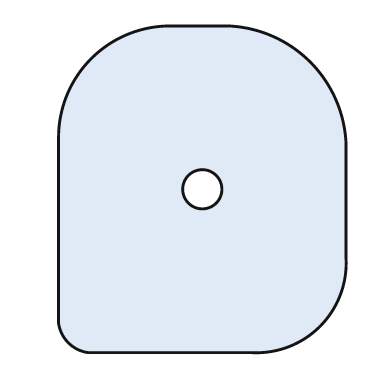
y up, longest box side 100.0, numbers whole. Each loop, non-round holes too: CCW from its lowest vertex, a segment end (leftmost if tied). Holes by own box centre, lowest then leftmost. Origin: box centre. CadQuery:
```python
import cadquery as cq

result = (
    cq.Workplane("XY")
    .moveTo(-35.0, -50.0)
    .lineTo(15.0, -50.0)
    .threePointArc((36.0, -42.0), (44.0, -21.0))
    .lineTo(44.0, 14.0)
    .threePointArc((33.0, 39.0), (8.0, 50.0))
    .lineTo(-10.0, 50.0)
    .threePointArc((-34.0, 40.0), (-44.0, 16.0))
    .lineTo(-44.0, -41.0)
    .threePointArc((-41.0, -47.0), (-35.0, -50.0))
    .close()
    .moveTo(0.0, 0.0)
    .circle(6.0)
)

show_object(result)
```